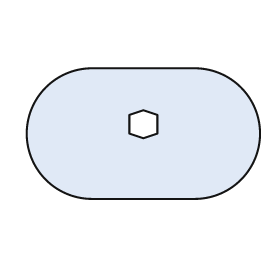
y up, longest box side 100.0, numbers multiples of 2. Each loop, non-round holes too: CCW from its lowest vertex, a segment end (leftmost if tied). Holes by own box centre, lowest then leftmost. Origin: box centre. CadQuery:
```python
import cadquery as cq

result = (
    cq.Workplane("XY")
    .moveTo(-22.0, -28.0)
    .lineTo(22.0, -28.0)
    .threePointArc((50.0, 0.0), (22.0, 28.0))
    .lineTo(-22.0, 28.0)
    .threePointArc((-50.0, 0.0), (-22.0, -28.0))
    .close()
    .moveTo(0.0, -2.0)
    .lineTo(6.0, 0.0)
    .lineTo(6.0, 8.0)
    .lineTo(0.0, 10.0)
    .lineTo(-6.0, 8.0)
    .lineTo(-6.0, 0.0)
    .close()
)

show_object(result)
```